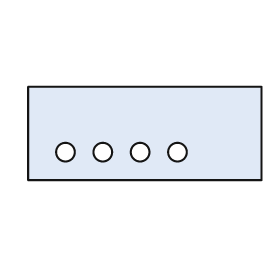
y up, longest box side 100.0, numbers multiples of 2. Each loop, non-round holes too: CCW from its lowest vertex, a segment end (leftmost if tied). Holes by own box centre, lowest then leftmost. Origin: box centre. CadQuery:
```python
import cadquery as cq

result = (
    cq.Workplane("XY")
    .moveTo(-50.0, -20.0)
    .lineTo(50.0, -20.0)
    .lineTo(50.0, 20.0)
    .lineTo(-50.0, 20.0)
    .close()
    .moveTo(-34.0, -8.0)
    .circle(4.0)
    .moveTo(-18.0, -8.0)
    .circle(4.0)
    .moveTo(-2.0, -8.0)
    .circle(4.0)
    .moveTo(14.0, -8.0)
    .circle(4.0)
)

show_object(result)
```